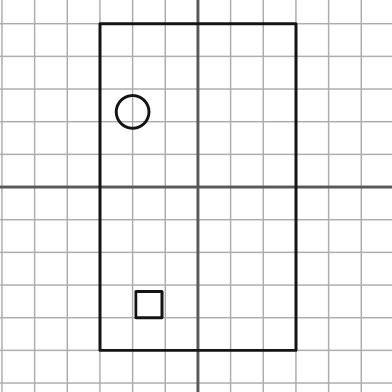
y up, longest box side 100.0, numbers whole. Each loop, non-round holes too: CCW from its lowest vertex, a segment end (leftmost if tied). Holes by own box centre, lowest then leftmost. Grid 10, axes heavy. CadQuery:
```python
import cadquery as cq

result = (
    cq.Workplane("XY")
    .moveTo(-30.0, -50.0)
    .lineTo(30.0, -50.0)
    .lineTo(30.0, 50.0)
    .lineTo(-30.0, 50.0)
    .close()
    .moveTo(-19.0, -40.0)
    .lineTo(-11.0, -40.0)
    .lineTo(-11.0, -32.0)
    .lineTo(-19.0, -32.0)
    .close()
    .moveTo(-20.0, 23.0)
    .circle(5.0)
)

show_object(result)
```